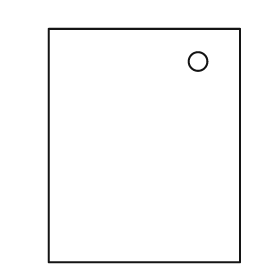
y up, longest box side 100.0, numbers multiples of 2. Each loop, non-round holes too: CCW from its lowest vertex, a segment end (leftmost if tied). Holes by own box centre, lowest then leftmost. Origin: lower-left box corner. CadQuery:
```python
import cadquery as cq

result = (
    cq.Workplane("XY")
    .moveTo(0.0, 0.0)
    .lineTo(82.0, 0.0)
    .lineTo(82.0, 100.0)
    .lineTo(0.0, 100.0)
    .close()
    .moveTo(64.0, 86.0)
    .circle(4.0)
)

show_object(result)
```